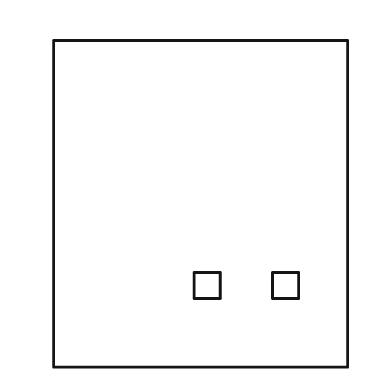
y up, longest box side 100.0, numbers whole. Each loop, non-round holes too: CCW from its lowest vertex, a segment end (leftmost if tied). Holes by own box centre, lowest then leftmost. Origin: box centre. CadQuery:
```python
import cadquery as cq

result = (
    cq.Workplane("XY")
    .moveTo(-45.0, -50.0)
    .lineTo(45.0, -50.0)
    .lineTo(45.0, 50.0)
    .lineTo(-45.0, 50.0)
    .close()
    .moveTo(-2.0, -29.0)
    .lineTo(6.0, -29.0)
    .lineTo(6.0, -21.0)
    .lineTo(-2.0, -21.0)
    .close()
    .moveTo(22.0, -29.0)
    .lineTo(30.0, -29.0)
    .lineTo(30.0, -21.0)
    .lineTo(22.0, -21.0)
    .close()
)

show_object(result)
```